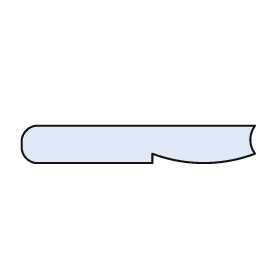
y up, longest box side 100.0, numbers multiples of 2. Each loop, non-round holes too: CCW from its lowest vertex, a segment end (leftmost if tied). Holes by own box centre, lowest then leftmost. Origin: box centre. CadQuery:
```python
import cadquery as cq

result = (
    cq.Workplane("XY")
    .moveTo(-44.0, -8.0)
    .lineTo(6.0, -8.0)
    .lineTo(6.0, -4.0)
    .threePointArc((28.0, -8.0), (50.0, -4.0))
    .threePointArc((48.0, 2.0), (50.0, 8.0))
    .lineTo(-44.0, 8.0)
    .threePointArc((-48.0, 6.0), (-50.0, 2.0))
    .lineTo(-50.0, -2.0)
    .threePointArc((-48.0, -6.0), (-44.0, -8.0))
    .close()
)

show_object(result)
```